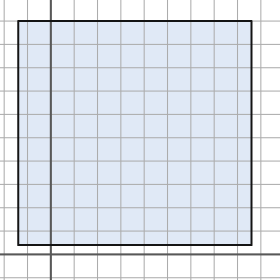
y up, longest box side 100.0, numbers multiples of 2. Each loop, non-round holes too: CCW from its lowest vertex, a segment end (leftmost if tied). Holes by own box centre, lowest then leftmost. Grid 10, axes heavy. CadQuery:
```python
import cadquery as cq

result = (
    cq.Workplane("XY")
    .moveTo(-14.0, 4.0)
    .lineTo(86.0, 4.0)
    .lineTo(86.0, 100.0)
    .lineTo(-14.0, 100.0)
    .close()
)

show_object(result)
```